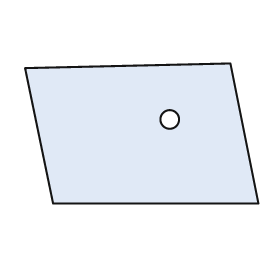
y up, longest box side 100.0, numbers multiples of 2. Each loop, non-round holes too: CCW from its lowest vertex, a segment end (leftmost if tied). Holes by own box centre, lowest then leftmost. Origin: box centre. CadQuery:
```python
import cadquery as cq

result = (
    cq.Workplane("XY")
    .moveTo(-38.0, -30.0)
    .lineTo(50.0, -30.0)
    .lineTo(38.0, 30.0)
    .lineTo(-50.0, 28.0)
    .close()
    .moveTo(12.0, 6.0)
    .circle(4.0)
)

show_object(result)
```